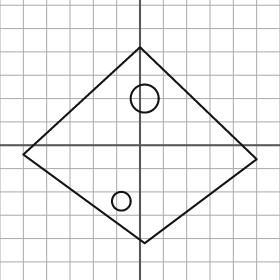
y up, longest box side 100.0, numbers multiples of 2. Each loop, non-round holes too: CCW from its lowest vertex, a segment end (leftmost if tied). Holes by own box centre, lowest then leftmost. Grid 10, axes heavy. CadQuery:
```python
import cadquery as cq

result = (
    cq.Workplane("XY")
    .moveTo(2.0, -42.0)
    .lineTo(50.0, -6.0)
    .lineTo(0.0, 42.0)
    .lineTo(-50.0, -4.0)
    .close()
    .moveTo(-8.0, -24.0)
    .circle(4.0)
    .moveTo(2.0, 20.0)
    .circle(6.0)
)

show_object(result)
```